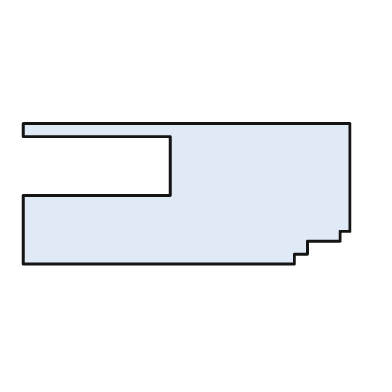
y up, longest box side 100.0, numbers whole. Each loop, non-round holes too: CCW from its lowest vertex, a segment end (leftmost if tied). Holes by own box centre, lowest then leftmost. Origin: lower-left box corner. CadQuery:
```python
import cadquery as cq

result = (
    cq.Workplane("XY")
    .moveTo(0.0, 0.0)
    .lineTo(83.0, 0.0)
    .lineTo(83.0, 3.0)
    .lineTo(87.0, 3.0)
    .lineTo(87.0, 7.0)
    .lineTo(97.0, 7.0)
    .lineTo(97.0, 10.0)
    .lineTo(100.0, 10.0)
    .lineTo(100.0, 43.0)
    .lineTo(0.0, 43.0)
    .lineTo(0.0, 39.0)
    .lineTo(45.0, 39.0)
    .lineTo(45.0, 21.0)
    .lineTo(0.0, 21.0)
    .close()
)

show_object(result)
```